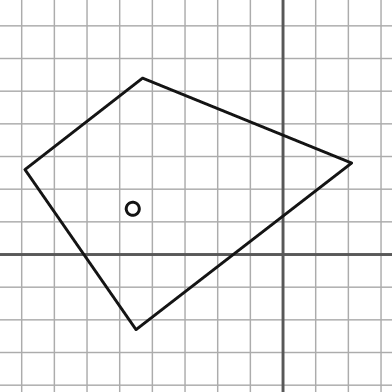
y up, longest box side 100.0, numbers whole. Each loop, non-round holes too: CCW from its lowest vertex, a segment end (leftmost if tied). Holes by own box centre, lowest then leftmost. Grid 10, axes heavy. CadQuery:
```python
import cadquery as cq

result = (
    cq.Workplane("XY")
    .moveTo(-45.0, -23.0)
    .lineTo(21.0, 28.0)
    .lineTo(-43.0, 54.0)
    .lineTo(-79.0, 26.0)
    .close()
    .moveTo(-46.0, 14.0)
    .circle(2.0)
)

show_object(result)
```